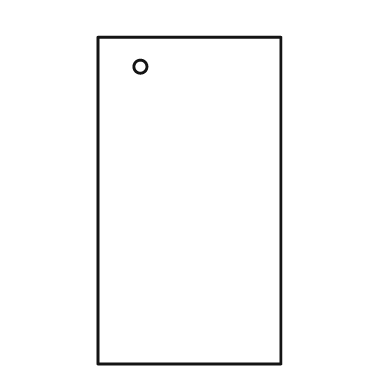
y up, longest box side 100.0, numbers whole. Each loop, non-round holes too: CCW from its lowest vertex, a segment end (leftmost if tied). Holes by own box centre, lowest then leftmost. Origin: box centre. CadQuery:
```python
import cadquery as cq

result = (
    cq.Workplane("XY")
    .moveTo(-28.0, -50.0)
    .lineTo(28.0, -50.0)
    .lineTo(28.0, 50.0)
    .lineTo(-28.0, 50.0)
    .close()
    .moveTo(-15.0, 41.0)
    .circle(2.0)
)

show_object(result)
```